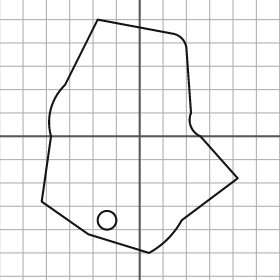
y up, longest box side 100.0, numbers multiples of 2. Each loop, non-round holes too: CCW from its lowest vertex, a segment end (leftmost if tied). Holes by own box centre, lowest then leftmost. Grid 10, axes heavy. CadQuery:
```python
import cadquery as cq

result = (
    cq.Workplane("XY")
    .moveTo(4.0, -50.0)
    .threePointArc((12.0, -44.0), (18.0, -36.0))
    .lineTo(42.0, -18.0)
    .lineTo(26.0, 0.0)
    .threePointArc((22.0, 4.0), (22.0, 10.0))
    .lineTo(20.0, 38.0)
    .threePointArc((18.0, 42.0), (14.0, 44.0))
    .lineTo(-18.0, 50.0)
    .lineTo(-32.0, 22.0)
    .threePointArc((-38.0, 12.0), (-38.0, 0.0))
    .lineTo(-42.0, -28.0)
    .lineTo(-22.0, -42.0)
    .close()
    .moveTo(-14.0, -36.0)
    .circle(4.0)
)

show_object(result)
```